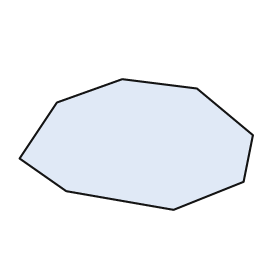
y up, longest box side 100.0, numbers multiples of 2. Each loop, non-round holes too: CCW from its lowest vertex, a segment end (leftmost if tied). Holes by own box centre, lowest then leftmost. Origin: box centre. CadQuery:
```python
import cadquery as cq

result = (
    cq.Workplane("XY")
    .moveTo(16.0, -28.0)
    .lineTo(46.0, -16.0)
    .lineTo(50.0, 4.0)
    .lineTo(26.0, 24.0)
    .lineTo(-6.0, 28.0)
    .lineTo(-34.0, 18.0)
    .lineTo(-50.0, -6.0)
    .lineTo(-30.0, -20.0)
    .close()
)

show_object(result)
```